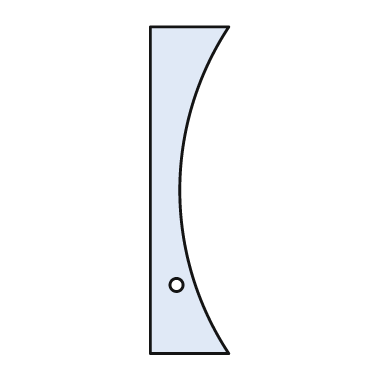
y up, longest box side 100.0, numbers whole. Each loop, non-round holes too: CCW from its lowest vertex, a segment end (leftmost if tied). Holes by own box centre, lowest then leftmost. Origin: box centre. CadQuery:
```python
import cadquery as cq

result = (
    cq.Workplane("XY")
    .moveTo(-12.0, -50.0)
    .lineTo(12.0, -50.0)
    .threePointArc((-3.0, 0.0), (12.0, 50.0))
    .lineTo(-12.0, 50.0)
    .close()
    .moveTo(-4.0, -29.0)
    .circle(2.0)
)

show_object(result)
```